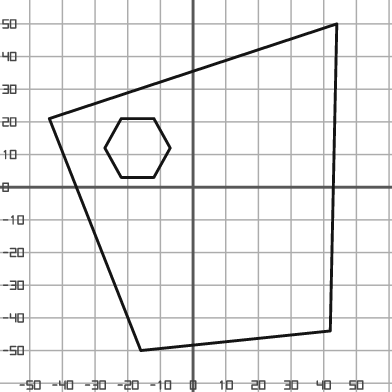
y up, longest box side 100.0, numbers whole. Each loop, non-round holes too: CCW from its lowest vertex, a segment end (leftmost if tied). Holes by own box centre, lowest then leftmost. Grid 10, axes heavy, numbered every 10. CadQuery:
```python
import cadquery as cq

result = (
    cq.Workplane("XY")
    .moveTo(-16.0, -50.0)
    .lineTo(42.0, -44.0)
    .lineTo(44.0, 50.0)
    .lineTo(-44.0, 21.0)
    .close()
    .moveTo(-22.0, 3.0)
    .lineTo(-12.0, 3.0)
    .lineTo(-7.0, 12.0)
    .lineTo(-12.0, 21.0)
    .lineTo(-22.0, 21.0)
    .lineTo(-27.0, 12.0)
    .close()
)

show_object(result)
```